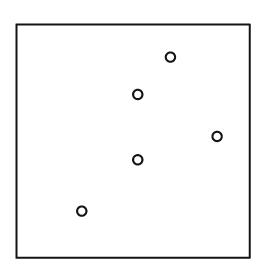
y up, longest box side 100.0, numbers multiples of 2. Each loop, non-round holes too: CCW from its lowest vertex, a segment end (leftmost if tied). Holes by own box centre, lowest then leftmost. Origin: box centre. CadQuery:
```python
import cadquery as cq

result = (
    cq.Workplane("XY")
    .moveTo(-50.0, -50.0)
    .lineTo(50.0, -50.0)
    .lineTo(50.0, 50.0)
    .lineTo(-50.0, 50.0)
    .close()
    .moveTo(-22.0, -30.0)
    .circle(2.0)
    .moveTo(2.0, -8.0)
    .circle(2.0)
    .moveTo(36.0, 2.0)
    .circle(2.0)
    .moveTo(2.0, 20.0)
    .circle(2.0)
    .moveTo(16.0, 36.0)
    .circle(2.0)
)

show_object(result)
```